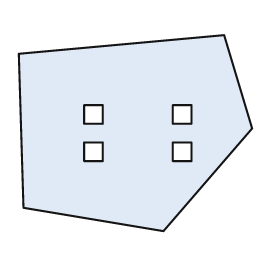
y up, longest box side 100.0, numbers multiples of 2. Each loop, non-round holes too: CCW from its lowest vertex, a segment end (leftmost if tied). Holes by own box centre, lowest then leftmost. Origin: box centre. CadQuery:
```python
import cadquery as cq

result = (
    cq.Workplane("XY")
    .moveTo(12.0, -42.0)
    .lineTo(50.0, 2.0)
    .lineTo(38.0, 42.0)
    .lineTo(-50.0, 34.0)
    .lineTo(-48.0, -32.0)
    .close()
    .moveTo(-22.0, -12.0)
    .lineTo(-14.0, -12.0)
    .lineTo(-14.0, -4.0)
    .lineTo(-22.0, -4.0)
    .close()
    .moveTo(16.0, -12.0)
    .lineTo(24.0, -12.0)
    .lineTo(24.0, -4.0)
    .lineTo(16.0, -4.0)
    .close()
    .moveTo(-22.0, 4.0)
    .lineTo(-14.0, 4.0)
    .lineTo(-14.0, 12.0)
    .lineTo(-22.0, 12.0)
    .close()
    .moveTo(16.0, 4.0)
    .lineTo(24.0, 4.0)
    .lineTo(24.0, 12.0)
    .lineTo(16.0, 12.0)
    .close()
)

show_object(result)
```